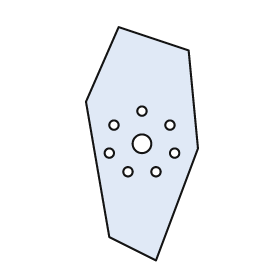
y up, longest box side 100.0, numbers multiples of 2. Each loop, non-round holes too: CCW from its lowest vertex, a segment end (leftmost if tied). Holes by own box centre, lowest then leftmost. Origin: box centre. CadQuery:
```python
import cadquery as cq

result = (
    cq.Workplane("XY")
    .moveTo(6.0, -50.0)
    .lineTo(24.0, -2.0)
    .lineTo(20.0, 40.0)
    .lineTo(-10.0, 50.0)
    .lineTo(-24.0, 18.0)
    .lineTo(-14.0, -40.0)
    .close()
    .moveTo(-6.0, -12.0)
    .circle(2.0)
    .moveTo(6.0, -12.0)
    .circle(2.0)
    .moveTo(-14.0, -4.0)
    .circle(2.0)
    .moveTo(14.0, -4.0)
    .circle(2.0)
    .moveTo(0.0, 0.0)
    .circle(4.0)
    .moveTo(-12.0, 8.0)
    .circle(2.0)
    .moveTo(12.0, 8.0)
    .circle(2.0)
    .moveTo(0.0, 14.0)
    .circle(2.0)
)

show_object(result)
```